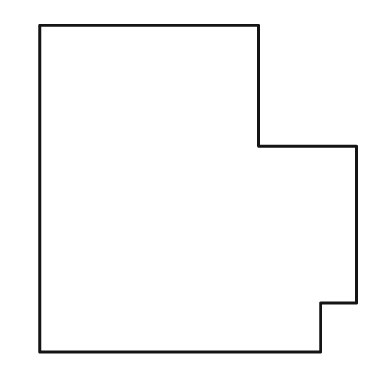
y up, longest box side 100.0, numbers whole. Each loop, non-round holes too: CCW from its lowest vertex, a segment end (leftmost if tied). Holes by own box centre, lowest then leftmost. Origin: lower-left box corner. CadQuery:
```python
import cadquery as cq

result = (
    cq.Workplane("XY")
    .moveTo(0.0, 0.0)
    .lineTo(86.0, 0.0)
    .lineTo(86.0, 15.0)
    .lineTo(97.0, 15.0)
    .lineTo(97.0, 63.0)
    .lineTo(67.0, 63.0)
    .lineTo(67.0, 100.0)
    .lineTo(0.0, 100.0)
    .close()
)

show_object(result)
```